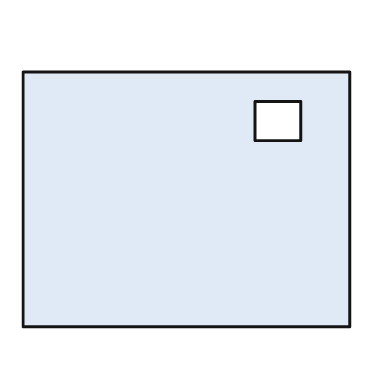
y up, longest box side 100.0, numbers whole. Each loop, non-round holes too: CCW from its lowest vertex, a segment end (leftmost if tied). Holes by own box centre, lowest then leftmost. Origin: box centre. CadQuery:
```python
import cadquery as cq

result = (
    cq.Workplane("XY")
    .moveTo(-50.0, -39.0)
    .lineTo(50.0, -39.0)
    .lineTo(50.0, 39.0)
    .lineTo(-50.0, 39.0)
    .close()
    .moveTo(21.0, 18.0)
    .lineTo(35.0, 18.0)
    .lineTo(35.0, 30.0)
    .lineTo(21.0, 30.0)
    .close()
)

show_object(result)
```